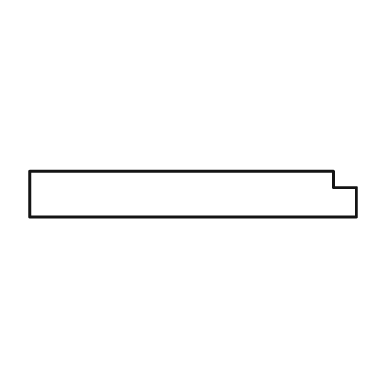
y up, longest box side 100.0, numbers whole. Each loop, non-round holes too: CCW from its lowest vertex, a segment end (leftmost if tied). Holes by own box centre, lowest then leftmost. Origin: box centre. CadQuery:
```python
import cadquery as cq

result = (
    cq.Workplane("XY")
    .moveTo(-50.0, -7.0)
    .lineTo(50.0, -7.0)
    .lineTo(50.0, 2.0)
    .lineTo(43.0, 2.0)
    .lineTo(43.0, 7.0)
    .lineTo(-50.0, 7.0)
    .close()
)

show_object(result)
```